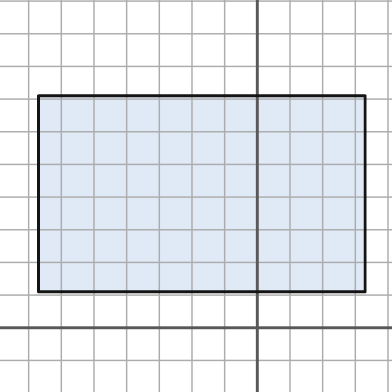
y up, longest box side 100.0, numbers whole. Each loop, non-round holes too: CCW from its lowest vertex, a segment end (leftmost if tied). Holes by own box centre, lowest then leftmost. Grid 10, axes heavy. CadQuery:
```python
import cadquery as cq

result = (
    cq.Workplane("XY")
    .moveTo(-67.0, 11.0)
    .lineTo(33.0, 11.0)
    .lineTo(33.0, 71.0)
    .lineTo(-67.0, 71.0)
    .close()
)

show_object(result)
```